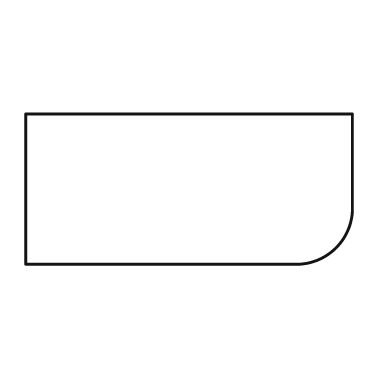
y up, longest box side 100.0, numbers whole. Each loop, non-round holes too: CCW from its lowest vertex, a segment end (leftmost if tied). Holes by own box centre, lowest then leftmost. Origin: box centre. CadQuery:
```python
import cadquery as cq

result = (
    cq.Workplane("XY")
    .moveTo(-50.0, -23.0)
    .lineTo(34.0, -23.0)
    .threePointArc((45.0, -18.0), (50.0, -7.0))
    .lineTo(50.0, 23.0)
    .lineTo(-50.0, 23.0)
    .close()
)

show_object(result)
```